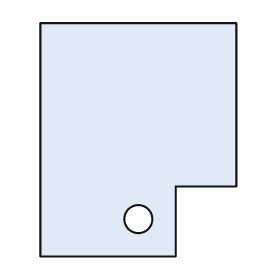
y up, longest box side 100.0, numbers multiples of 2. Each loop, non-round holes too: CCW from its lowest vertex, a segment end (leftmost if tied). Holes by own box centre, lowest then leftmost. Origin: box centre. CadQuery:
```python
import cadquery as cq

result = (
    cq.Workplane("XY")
    .moveTo(-42.0, -50.0)
    .lineTo(16.0, -50.0)
    .lineTo(16.0, -20.0)
    .lineTo(42.0, -20.0)
    .lineTo(42.0, 50.0)
    .lineTo(-42.0, 50.0)
    .close()
    .moveTo(0.0, -34.0)
    .circle(6.0)
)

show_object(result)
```